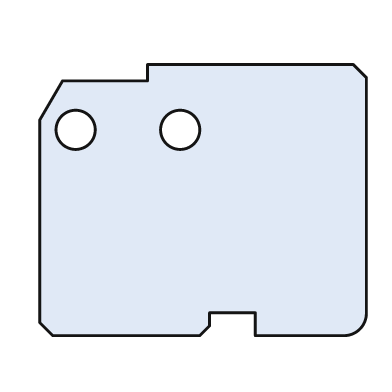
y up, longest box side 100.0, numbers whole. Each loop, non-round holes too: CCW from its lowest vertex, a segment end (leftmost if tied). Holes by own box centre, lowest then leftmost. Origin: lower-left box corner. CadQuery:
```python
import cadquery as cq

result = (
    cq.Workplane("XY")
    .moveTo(4.0, 0.0)
    .lineTo(49.0, 0.0)
    .lineTo(52.0, 3.0)
    .lineTo(52.0, 7.0)
    .lineTo(66.0, 7.0)
    .lineTo(66.0, 0.0)
    .lineTo(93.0, 0.0)
    .threePointArc((98.0, 2.0), (100.0, 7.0))
    .lineTo(100.0, 79.0)
    .lineTo(96.0, 83.0)
    .lineTo(33.0, 83.0)
    .lineTo(33.0, 78.0)
    .lineTo(7.0, 78.0)
    .lineTo(0.0, 66.0)
    .lineTo(0.0, 4.0)
    .close()
    .moveTo(11.0, 63.0)
    .circle(6.0)
    .moveTo(43.0, 63.0)
    .circle(6.0)
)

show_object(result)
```